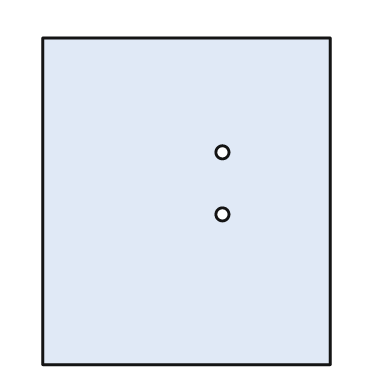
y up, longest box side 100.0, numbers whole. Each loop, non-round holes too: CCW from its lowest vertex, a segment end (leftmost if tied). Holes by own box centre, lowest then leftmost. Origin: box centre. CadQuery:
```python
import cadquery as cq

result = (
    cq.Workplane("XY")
    .moveTo(-44.0, -50.0)
    .lineTo(44.0, -50.0)
    .lineTo(44.0, 50.0)
    .lineTo(-44.0, 50.0)
    .close()
    .moveTo(11.0, -4.0)
    .circle(2.0)
    .moveTo(11.0, 15.0)
    .circle(2.0)
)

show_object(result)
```